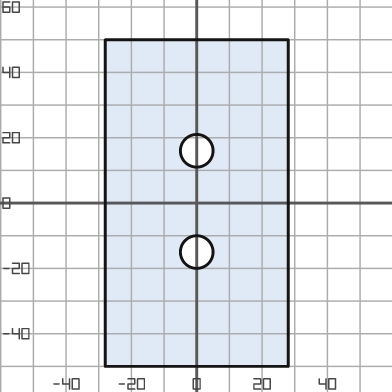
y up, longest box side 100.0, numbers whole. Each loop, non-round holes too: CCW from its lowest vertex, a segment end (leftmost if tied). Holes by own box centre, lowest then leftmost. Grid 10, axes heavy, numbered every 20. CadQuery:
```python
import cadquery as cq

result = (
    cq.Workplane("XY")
    .moveTo(-28.0, -50.0)
    .lineTo(28.0, -50.0)
    .lineTo(28.0, 50.0)
    .lineTo(-28.0, 50.0)
    .close()
    .moveTo(0.0, -15.0)
    .circle(5.0)
    .moveTo(0.0, 16.0)
    .circle(5.0)
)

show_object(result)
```